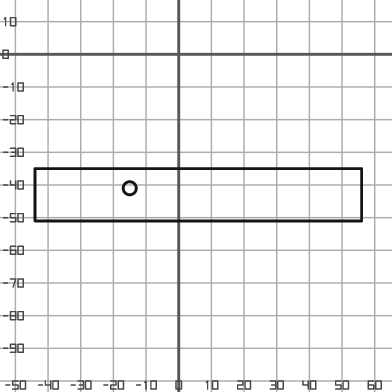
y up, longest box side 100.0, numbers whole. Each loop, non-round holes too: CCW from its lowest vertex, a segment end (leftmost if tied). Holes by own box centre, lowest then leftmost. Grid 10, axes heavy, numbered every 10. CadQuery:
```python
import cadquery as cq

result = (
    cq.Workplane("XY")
    .moveTo(-44.0, -51.0)
    .lineTo(56.0, -51.0)
    .lineTo(56.0, -35.0)
    .lineTo(-44.0, -35.0)
    .close()
    .moveTo(-15.0, -41.0)
    .circle(2.0)
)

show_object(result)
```